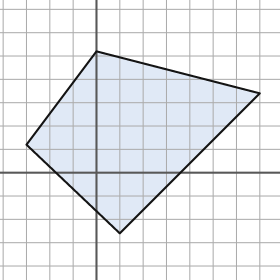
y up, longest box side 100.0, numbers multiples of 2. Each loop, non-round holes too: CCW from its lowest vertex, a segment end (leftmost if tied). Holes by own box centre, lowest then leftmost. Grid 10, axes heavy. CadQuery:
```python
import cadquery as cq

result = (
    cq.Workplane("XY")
    .moveTo(10.0, -26.0)
    .lineTo(70.0, 34.0)
    .lineTo(0.0, 52.0)
    .lineTo(-30.0, 12.0)
    .close()
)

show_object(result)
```